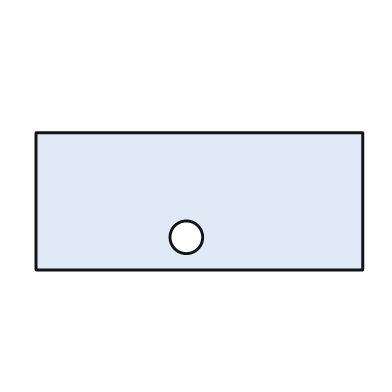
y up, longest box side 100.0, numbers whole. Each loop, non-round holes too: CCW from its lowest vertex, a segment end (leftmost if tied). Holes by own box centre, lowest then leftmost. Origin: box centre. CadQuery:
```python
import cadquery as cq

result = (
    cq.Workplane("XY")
    .moveTo(-50.0, -21.0)
    .lineTo(50.0, -21.0)
    .lineTo(50.0, 21.0)
    .lineTo(-50.0, 21.0)
    .close()
    .moveTo(-4.0, -11.0)
    .circle(5.0)
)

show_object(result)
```